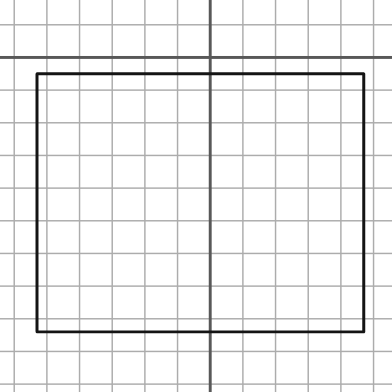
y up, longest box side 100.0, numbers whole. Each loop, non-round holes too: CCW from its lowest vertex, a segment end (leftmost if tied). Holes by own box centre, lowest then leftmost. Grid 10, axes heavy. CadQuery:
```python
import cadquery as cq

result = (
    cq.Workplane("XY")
    .moveTo(-53.0, -84.0)
    .lineTo(47.0, -84.0)
    .lineTo(47.0, -5.0)
    .lineTo(-53.0, -5.0)
    .close()
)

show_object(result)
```